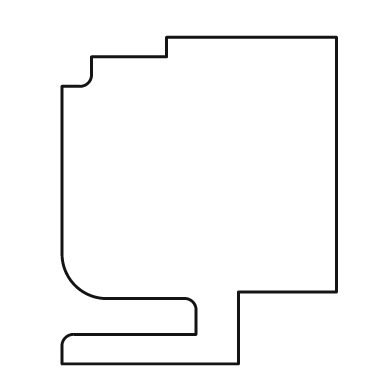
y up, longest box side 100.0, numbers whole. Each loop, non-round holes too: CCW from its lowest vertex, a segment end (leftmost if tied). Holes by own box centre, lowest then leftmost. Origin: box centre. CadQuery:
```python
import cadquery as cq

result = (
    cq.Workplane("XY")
    .moveTo(-42.0, -50.0)
    .lineTo(12.0, -50.0)
    .lineTo(12.0, -28.0)
    .lineTo(42.0, -28.0)
    .lineTo(42.0, 50.0)
    .lineTo(-10.0, 50.0)
    .lineTo(-10.0, 44.0)
    .lineTo(-33.0, 44.0)
    .lineTo(-33.0, 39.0)
    .threePointArc((-34.0, 36.0), (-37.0, 35.0))
    .lineTo(-42.0, 35.0)
    .lineTo(-42.0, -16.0)
    .threePointArc((-38.0, -26.0), (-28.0, -30.0))
    .lineTo(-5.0, -30.0)
    .threePointArc((-2.0, -31.0), (-1.0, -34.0))
    .lineTo(-1.0, -41.0)
    .lineTo(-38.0, -41.0)
    .threePointArc((-41.0, -42.0), (-42.0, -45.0))
    .close()
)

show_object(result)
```